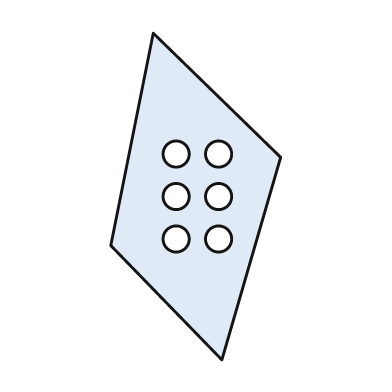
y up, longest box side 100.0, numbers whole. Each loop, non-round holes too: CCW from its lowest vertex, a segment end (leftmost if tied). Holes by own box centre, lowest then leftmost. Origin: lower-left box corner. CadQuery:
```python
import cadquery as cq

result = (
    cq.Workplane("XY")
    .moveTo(34.0, 0.0)
    .lineTo(52.0, 62.0)
    .lineTo(13.0, 100.0)
    .lineTo(0.0, 35.0)
    .close()
    .moveTo(20.0, 37.0)
    .circle(4.0)
    .moveTo(33.0, 37.0)
    .circle(4.0)
    .moveTo(20.0, 50.0)
    .circle(4.0)
    .moveTo(33.0, 50.0)
    .circle(4.0)
    .moveTo(20.0, 63.0)
    .circle(4.0)
    .moveTo(33.0, 63.0)
    .circle(4.0)
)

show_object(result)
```